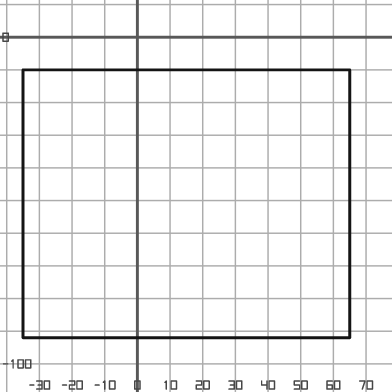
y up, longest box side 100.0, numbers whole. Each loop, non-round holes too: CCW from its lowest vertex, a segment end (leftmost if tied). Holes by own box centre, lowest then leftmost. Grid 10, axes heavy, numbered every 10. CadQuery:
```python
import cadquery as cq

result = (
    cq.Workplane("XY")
    .moveTo(-35.0, -92.0)
    .lineTo(65.0, -92.0)
    .lineTo(65.0, -10.0)
    .lineTo(-35.0, -10.0)
    .close()
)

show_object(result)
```